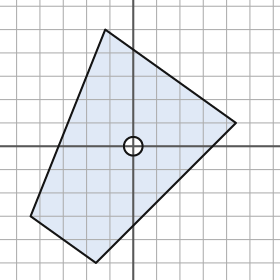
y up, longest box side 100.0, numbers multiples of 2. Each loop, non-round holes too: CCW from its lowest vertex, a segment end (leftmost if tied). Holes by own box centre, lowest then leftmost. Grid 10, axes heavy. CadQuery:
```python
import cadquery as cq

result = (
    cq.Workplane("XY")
    .moveTo(-16.0, -50.0)
    .lineTo(44.0, 10.0)
    .lineTo(-12.0, 50.0)
    .lineTo(-44.0, -30.0)
    .close()
    .moveTo(0.0, 0.0)
    .circle(4.0)
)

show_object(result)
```